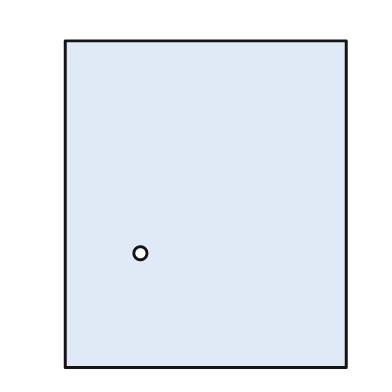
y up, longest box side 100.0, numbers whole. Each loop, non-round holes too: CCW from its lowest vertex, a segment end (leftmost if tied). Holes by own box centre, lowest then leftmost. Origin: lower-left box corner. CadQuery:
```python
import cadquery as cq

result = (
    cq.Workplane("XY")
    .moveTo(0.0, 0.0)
    .lineTo(86.0, 0.0)
    .lineTo(86.0, 100.0)
    .lineTo(0.0, 100.0)
    .close()
    .moveTo(23.0, 35.0)
    .circle(2.0)
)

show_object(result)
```